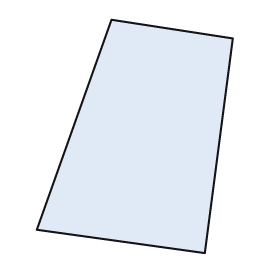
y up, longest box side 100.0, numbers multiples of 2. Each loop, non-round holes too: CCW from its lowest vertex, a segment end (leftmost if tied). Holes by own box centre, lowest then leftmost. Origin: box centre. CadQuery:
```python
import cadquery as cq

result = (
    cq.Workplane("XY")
    .moveTo(30.0, -50.0)
    .lineTo(42.0, 42.0)
    .lineTo(-10.0, 50.0)
    .lineTo(-42.0, -40.0)
    .close()
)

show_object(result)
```